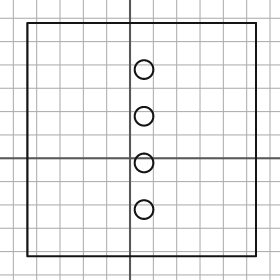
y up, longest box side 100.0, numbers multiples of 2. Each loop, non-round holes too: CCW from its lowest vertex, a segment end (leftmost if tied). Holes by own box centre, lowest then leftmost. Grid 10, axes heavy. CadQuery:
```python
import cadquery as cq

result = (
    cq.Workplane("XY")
    .moveTo(-44.0, -42.0)
    .lineTo(54.0, -42.0)
    .lineTo(54.0, 58.0)
    .lineTo(-44.0, 58.0)
    .close()
    .moveTo(6.0, -22.0)
    .circle(4.0)
    .moveTo(6.0, -2.0)
    .circle(4.0)
    .moveTo(6.0, 18.0)
    .circle(4.0)
    .moveTo(6.0, 38.0)
    .circle(4.0)
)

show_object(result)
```